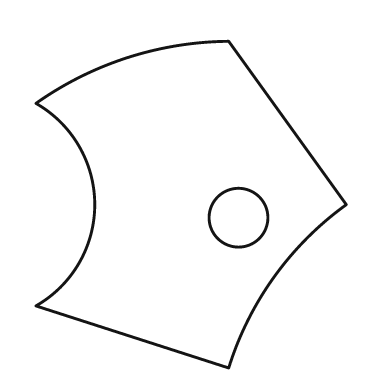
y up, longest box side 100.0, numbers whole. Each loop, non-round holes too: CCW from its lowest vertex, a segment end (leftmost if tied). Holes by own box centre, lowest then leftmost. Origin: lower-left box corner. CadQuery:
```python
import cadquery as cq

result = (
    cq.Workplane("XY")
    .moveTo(59.0, 0.0)
    .threePointArc((73.0, 28.0), (95.0, 50.0))
    .lineTo(59.0, 100.0)
    .threePointArc((28.0, 95.0), (0.0, 81.0))
    .threePointArc((18.0, 50.0), (0.0, 19.0))
    .close()
    .moveTo(62.0, 46.0)
    .circle(9.0)
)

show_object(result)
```